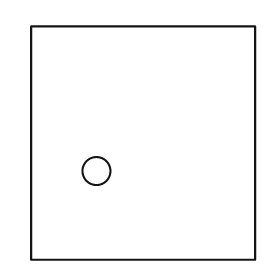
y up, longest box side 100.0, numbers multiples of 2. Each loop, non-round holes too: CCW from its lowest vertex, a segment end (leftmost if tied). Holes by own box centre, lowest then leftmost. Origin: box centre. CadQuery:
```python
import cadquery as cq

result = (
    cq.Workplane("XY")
    .moveTo(-48.0, -50.0)
    .lineTo(48.0, -50.0)
    .lineTo(48.0, 50.0)
    .lineTo(-48.0, 50.0)
    .close()
    .moveTo(-20.0, -12.0)
    .circle(6.0)
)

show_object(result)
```